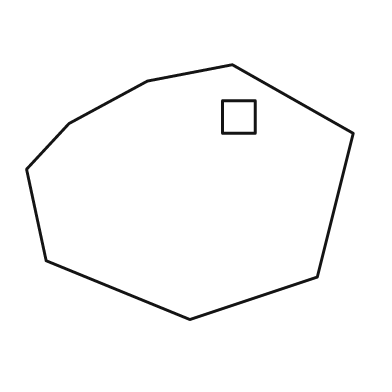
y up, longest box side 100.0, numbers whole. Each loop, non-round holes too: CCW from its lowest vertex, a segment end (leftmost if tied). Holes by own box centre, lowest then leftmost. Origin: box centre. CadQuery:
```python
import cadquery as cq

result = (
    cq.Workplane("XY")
    .moveTo(0.0, -39.0)
    .lineTo(39.0, -26.0)
    .lineTo(50.0, 18.0)
    .lineTo(13.0, 39.0)
    .lineTo(-13.0, 34.0)
    .lineTo(-37.0, 21.0)
    .lineTo(-50.0, 7.0)
    .lineTo(-44.0, -21.0)
    .close()
    .moveTo(10.0, 18.0)
    .lineTo(20.0, 18.0)
    .lineTo(20.0, 28.0)
    .lineTo(10.0, 28.0)
    .close()
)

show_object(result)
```